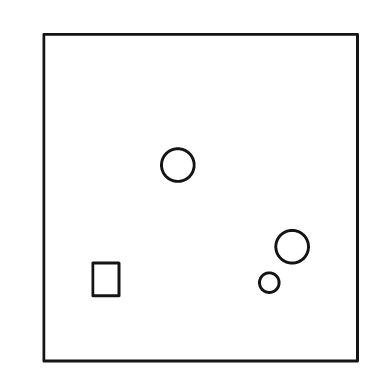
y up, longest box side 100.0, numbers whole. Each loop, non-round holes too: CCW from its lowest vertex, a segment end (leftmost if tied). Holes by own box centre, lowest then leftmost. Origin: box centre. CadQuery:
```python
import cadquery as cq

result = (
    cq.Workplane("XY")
    .moveTo(-48.0, -50.0)
    .lineTo(48.0, -50.0)
    .lineTo(48.0, 50.0)
    .lineTo(-48.0, 50.0)
    .close()
    .moveTo(21.0, -26.0)
    .circle(3.0)
    .moveTo(-33.0, -30.0)
    .lineTo(-25.0, -30.0)
    .lineTo(-25.0, -20.0)
    .lineTo(-33.0, -20.0)
    .close()
    .moveTo(28.0, -15.0)
    .circle(5.0)
    .moveTo(-7.0, 10.0)
    .circle(5.0)
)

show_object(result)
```